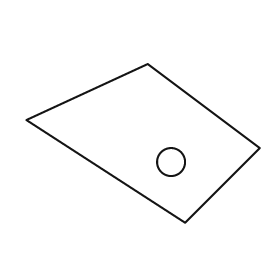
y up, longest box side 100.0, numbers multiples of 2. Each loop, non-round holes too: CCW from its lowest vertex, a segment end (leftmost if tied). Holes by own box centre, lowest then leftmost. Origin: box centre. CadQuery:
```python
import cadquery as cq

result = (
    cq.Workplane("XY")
    .moveTo(18.0, -34.0)
    .lineTo(50.0, -2.0)
    .lineTo(2.0, 34.0)
    .lineTo(-50.0, 10.0)
    .close()
    .moveTo(12.0, -8.0)
    .circle(6.0)
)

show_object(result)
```